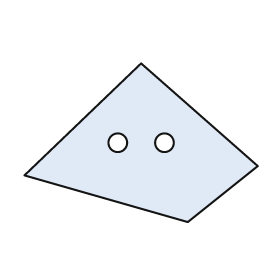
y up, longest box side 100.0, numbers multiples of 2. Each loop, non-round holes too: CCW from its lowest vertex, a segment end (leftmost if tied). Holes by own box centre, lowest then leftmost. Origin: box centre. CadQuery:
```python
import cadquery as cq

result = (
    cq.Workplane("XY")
    .moveTo(20.0, -34.0)
    .lineTo(50.0, -10.0)
    .lineTo(0.0, 34.0)
    .lineTo(-50.0, -14.0)
    .close()
    .moveTo(-10.0, 0.0)
    .circle(4.0)
    .moveTo(10.0, 0.0)
    .circle(4.0)
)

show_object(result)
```